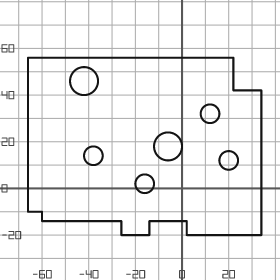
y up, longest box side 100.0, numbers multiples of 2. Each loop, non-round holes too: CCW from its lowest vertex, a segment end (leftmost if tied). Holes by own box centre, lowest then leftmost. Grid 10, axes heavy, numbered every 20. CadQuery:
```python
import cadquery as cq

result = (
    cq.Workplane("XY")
    .moveTo(-26.0, -20.0)
    .lineTo(-14.0, -20.0)
    .lineTo(-14.0, -14.0)
    .lineTo(2.0, -14.0)
    .lineTo(2.0, -20.0)
    .lineTo(34.0, -20.0)
    .lineTo(34.0, 42.0)
    .lineTo(22.0, 42.0)
    .lineTo(22.0, 56.0)
    .lineTo(-66.0, 56.0)
    .lineTo(-66.0, -10.0)
    .lineTo(-60.0, -10.0)
    .lineTo(-60.0, -14.0)
    .lineTo(-26.0, -14.0)
    .close()
    .moveTo(-16.0, 2.0)
    .circle(4.0)
    .moveTo(20.0, 12.0)
    .circle(4.0)
    .moveTo(-38.0, 14.0)
    .circle(4.0)
    .moveTo(-6.0, 18.0)
    .circle(6.0)
    .moveTo(12.0, 32.0)
    .circle(4.0)
    .moveTo(-42.0, 46.0)
    .circle(6.0)
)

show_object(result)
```